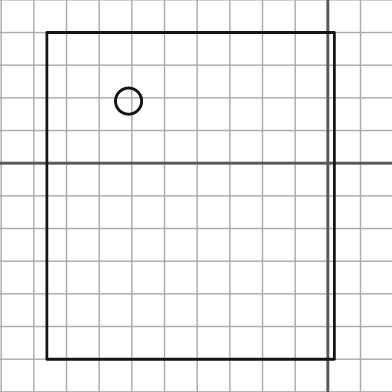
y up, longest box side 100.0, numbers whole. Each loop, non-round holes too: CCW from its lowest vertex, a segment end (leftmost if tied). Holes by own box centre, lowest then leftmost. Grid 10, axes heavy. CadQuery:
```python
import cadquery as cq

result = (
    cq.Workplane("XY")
    .moveTo(-86.0, -60.0)
    .lineTo(2.0, -60.0)
    .lineTo(2.0, 40.0)
    .lineTo(-86.0, 40.0)
    .close()
    .moveTo(-61.0, 19.0)
    .circle(4.0)
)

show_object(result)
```